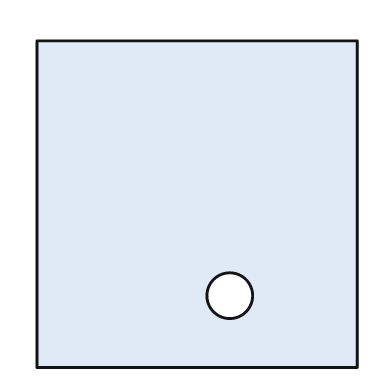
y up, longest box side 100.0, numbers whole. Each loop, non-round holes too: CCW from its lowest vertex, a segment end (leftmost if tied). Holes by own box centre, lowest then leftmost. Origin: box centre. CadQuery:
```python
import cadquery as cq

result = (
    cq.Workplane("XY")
    .moveTo(-49.0, -50.0)
    .lineTo(49.0, -50.0)
    .lineTo(49.0, 50.0)
    .lineTo(-49.0, 50.0)
    .close()
    .moveTo(10.0, -28.0)
    .circle(7.0)
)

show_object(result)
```